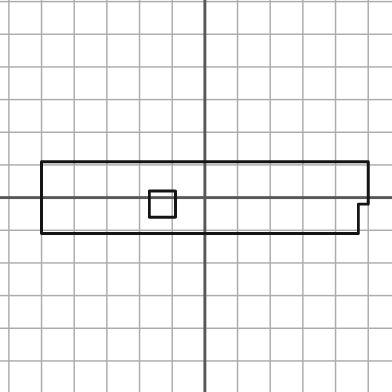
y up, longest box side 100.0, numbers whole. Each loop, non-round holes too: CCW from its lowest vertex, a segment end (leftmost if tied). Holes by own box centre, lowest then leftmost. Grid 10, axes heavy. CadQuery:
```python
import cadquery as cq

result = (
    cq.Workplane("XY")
    .moveTo(-50.0, -11.0)
    .lineTo(47.0, -11.0)
    .lineTo(47.0, -2.0)
    .lineTo(50.0, -2.0)
    .lineTo(50.0, 11.0)
    .lineTo(-50.0, 11.0)
    .close()
    .moveTo(-17.0, -6.0)
    .lineTo(-9.0, -6.0)
    .lineTo(-9.0, 2.0)
    .lineTo(-17.0, 2.0)
    .close()
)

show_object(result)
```